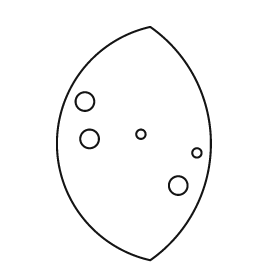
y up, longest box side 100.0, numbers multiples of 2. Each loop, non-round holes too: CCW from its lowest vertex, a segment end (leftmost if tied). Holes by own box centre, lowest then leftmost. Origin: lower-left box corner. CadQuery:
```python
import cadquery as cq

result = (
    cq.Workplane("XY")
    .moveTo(40.0, 0.0)
    .threePointArc((66.0, 50.0), (40.0, 100.0))
    .threePointArc((0.0, 50.0), (40.0, 0.0))
    .close()
    .moveTo(52.0, 32.0)
    .circle(4.0)
    .moveTo(60.0, 46.0)
    .circle(2.0)
    .moveTo(14.0, 52.0)
    .circle(4.0)
    .moveTo(36.0, 54.0)
    .circle(2.0)
    .moveTo(12.0, 68.0)
    .circle(4.0)
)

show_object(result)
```